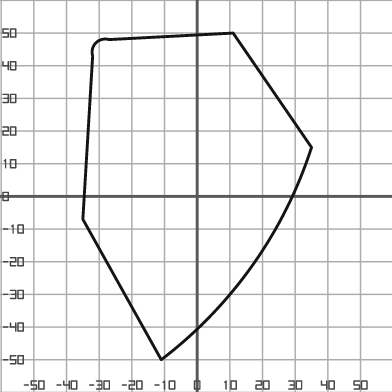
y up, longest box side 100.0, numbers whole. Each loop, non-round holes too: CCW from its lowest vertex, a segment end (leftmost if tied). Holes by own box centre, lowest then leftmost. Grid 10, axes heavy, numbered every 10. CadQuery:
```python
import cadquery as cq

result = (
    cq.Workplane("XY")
    .moveTo(-11.0, -50.0)
    .threePointArc((17.0, -21.0), (35.0, 15.0))
    .lineTo(11.0, 50.0)
    .lineTo(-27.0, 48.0)
    .threePointArc((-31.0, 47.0), (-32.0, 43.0))
    .lineTo(-35.0, -7.0)
    .close()
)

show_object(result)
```